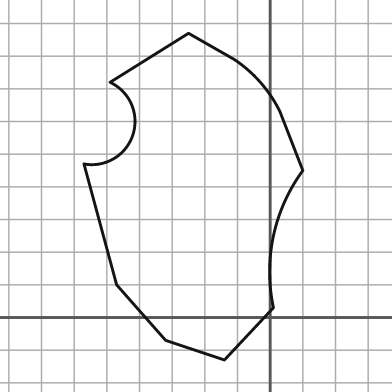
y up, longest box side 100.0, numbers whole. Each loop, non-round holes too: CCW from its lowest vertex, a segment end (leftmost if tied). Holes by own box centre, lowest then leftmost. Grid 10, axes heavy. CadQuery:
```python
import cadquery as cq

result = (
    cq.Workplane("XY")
    .moveTo(-14.0, -13.0)
    .lineTo(1.0, 3.0)
    .threePointArc((1.0, 25.0), (10.0, 45.0))
    .lineTo(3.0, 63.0)
    .threePointArc((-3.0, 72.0), (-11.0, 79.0))
    .lineTo(-25.0, 87.0)
    .lineTo(-49.0, 72.0)
    .threePointArc((-42.0, 56.0), (-57.0, 47.0))
    .lineTo(-47.0, 10.0)
    .lineTo(-32.0, -7.0)
    .close()
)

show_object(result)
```